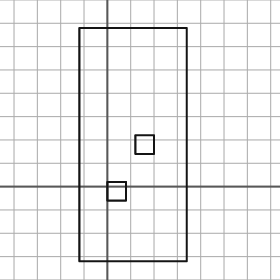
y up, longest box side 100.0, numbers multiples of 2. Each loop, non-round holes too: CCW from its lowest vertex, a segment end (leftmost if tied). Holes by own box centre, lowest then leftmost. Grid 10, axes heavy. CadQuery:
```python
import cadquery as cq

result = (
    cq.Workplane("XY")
    .moveTo(-12.0, -32.0)
    .lineTo(34.0, -32.0)
    .lineTo(34.0, 68.0)
    .lineTo(-12.0, 68.0)
    .close()
    .moveTo(0.0, -6.0)
    .lineTo(8.0, -6.0)
    .lineTo(8.0, 2.0)
    .lineTo(0.0, 2.0)
    .close()
    .moveTo(12.0, 14.0)
    .lineTo(20.0, 14.0)
    .lineTo(20.0, 22.0)
    .lineTo(12.0, 22.0)
    .close()
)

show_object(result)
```